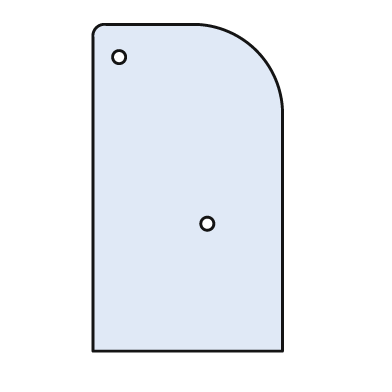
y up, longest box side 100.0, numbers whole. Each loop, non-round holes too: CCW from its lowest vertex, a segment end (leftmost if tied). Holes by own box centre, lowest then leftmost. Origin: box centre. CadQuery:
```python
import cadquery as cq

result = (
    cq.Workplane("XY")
    .moveTo(-29.0, -50.0)
    .lineTo(29.0, -50.0)
    .lineTo(29.0, 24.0)
    .threePointArc((21.0, 42.0), (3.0, 50.0))
    .lineTo(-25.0, 50.0)
    .threePointArc((-28.0, 49.0), (-29.0, 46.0))
    .close()
    .moveTo(6.0, -11.0)
    .circle(2.0)
    .moveTo(-21.0, 40.0)
    .circle(2.0)
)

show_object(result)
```